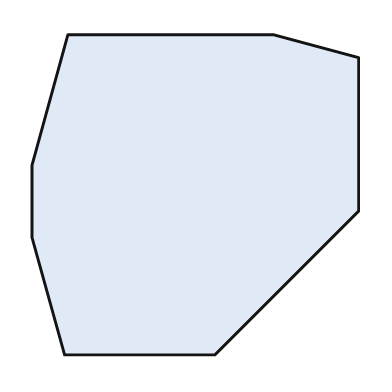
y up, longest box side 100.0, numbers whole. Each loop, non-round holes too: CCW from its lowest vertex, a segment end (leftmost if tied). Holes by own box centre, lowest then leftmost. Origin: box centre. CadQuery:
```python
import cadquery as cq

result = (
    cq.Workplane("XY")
    .moveTo(-40.0, -49.0)
    .lineTo(6.0, -49.0)
    .lineTo(50.0, -5.0)
    .lineTo(50.0, 42.0)
    .lineTo(24.0, 49.0)
    .lineTo(-39.0, 49.0)
    .lineTo(-50.0, 9.0)
    .lineTo(-50.0, -13.0)
    .close()
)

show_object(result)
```